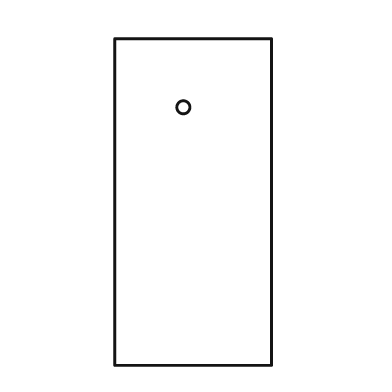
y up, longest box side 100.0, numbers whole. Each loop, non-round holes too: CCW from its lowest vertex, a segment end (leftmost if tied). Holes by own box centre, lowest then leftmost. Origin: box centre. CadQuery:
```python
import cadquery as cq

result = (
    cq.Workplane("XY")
    .moveTo(-24.0, -50.0)
    .lineTo(24.0, -50.0)
    .lineTo(24.0, 50.0)
    .lineTo(-24.0, 50.0)
    .close()
    .moveTo(-3.0, 29.0)
    .circle(2.0)
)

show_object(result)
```